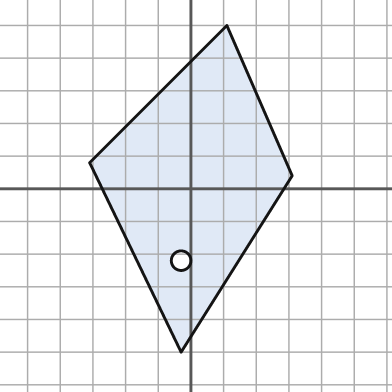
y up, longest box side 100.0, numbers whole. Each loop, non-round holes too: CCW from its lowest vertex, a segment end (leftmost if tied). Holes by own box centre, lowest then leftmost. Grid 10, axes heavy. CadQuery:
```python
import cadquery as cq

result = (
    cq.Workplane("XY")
    .moveTo(-3.0, -50.0)
    .lineTo(31.0, 4.0)
    .lineTo(11.0, 50.0)
    .lineTo(-31.0, 8.0)
    .close()
    .moveTo(-3.0, -22.0)
    .circle(3.0)
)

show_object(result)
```